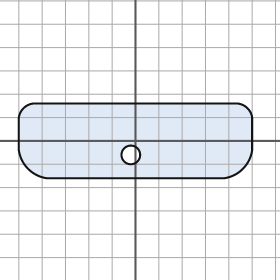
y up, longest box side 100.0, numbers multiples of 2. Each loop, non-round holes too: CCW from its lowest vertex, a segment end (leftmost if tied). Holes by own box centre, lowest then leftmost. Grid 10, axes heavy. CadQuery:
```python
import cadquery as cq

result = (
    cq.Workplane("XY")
    .moveTo(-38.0, -16.0)
    .lineTo(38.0, -16.0)
    .threePointArc((46.0, -12.0), (50.0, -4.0))
    .lineTo(50.0, 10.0)
    .threePointArc((48.0, 14.0), (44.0, 16.0))
    .lineTo(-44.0, 16.0)
    .threePointArc((-48.0, 14.0), (-50.0, 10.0))
    .lineTo(-50.0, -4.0)
    .threePointArc((-46.0, -12.0), (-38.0, -16.0))
    .close()
    .moveTo(-2.0, -6.0)
    .circle(4.0)
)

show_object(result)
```